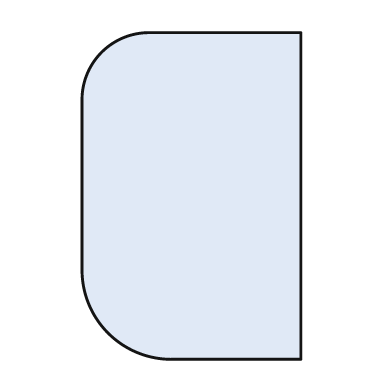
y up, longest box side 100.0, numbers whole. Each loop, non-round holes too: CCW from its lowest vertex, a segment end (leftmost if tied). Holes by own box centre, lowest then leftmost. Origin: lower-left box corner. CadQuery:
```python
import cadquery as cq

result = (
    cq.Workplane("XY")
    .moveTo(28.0, 0.0)
    .lineTo(67.0, 0.0)
    .lineTo(67.0, 100.0)
    .lineTo(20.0, 100.0)
    .threePointArc((6.0, 94.0), (0.0, 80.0))
    .lineTo(0.0, 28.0)
    .threePointArc((8.0, 8.0), (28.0, 0.0))
    .close()
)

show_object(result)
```